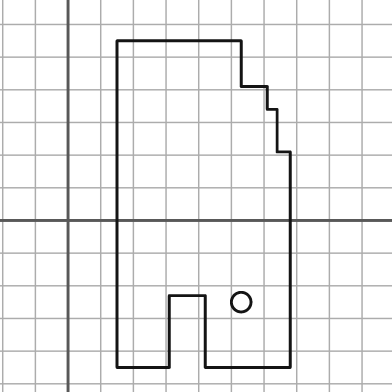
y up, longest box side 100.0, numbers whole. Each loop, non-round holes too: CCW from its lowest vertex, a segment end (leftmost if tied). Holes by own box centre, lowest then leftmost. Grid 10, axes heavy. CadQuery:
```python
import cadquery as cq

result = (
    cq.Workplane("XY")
    .moveTo(15.0, -45.0)
    .lineTo(31.0, -45.0)
    .lineTo(31.0, -23.0)
    .lineTo(42.0, -23.0)
    .lineTo(42.0, -45.0)
    .lineTo(68.0, -45.0)
    .lineTo(68.0, 21.0)
    .lineTo(64.0, 21.0)
    .lineTo(64.0, 34.0)
    .lineTo(61.0, 34.0)
    .lineTo(61.0, 41.0)
    .lineTo(53.0, 41.0)
    .lineTo(53.0, 55.0)
    .lineTo(15.0, 55.0)
    .close()
    .moveTo(53.0, -25.0)
    .circle(3.0)
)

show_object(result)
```